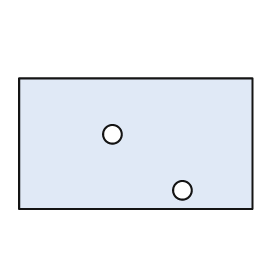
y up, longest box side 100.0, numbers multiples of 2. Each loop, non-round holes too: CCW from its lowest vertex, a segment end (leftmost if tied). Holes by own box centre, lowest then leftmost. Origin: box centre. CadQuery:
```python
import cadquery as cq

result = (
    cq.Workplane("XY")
    .moveTo(-50.0, -28.0)
    .lineTo(50.0, -28.0)
    .lineTo(50.0, 28.0)
    .lineTo(-50.0, 28.0)
    .close()
    .moveTo(20.0, -20.0)
    .circle(4.0)
    .moveTo(-10.0, 4.0)
    .circle(4.0)
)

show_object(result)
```